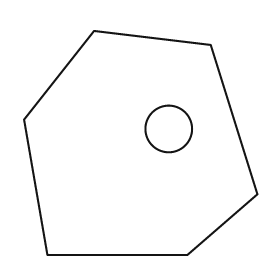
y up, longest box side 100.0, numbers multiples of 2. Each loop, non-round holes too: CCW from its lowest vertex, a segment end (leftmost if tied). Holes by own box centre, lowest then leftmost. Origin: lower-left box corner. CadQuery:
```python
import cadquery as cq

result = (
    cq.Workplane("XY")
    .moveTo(10.0, 0.0)
    .lineTo(70.0, 0.0)
    .lineTo(100.0, 26.0)
    .lineTo(80.0, 90.0)
    .lineTo(30.0, 96.0)
    .lineTo(0.0, 58.0)
    .close()
    .moveTo(62.0, 54.0)
    .circle(10.0)
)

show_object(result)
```